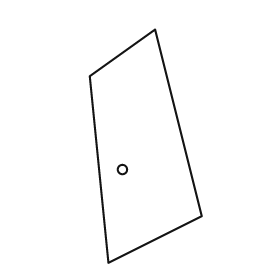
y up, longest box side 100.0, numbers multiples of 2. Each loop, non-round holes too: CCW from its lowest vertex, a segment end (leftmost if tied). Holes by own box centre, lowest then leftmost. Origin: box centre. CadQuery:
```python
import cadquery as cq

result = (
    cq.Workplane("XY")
    .moveTo(-16.0, -50.0)
    .lineTo(24.0, -30.0)
    .lineTo(4.0, 50.0)
    .lineTo(-24.0, 30.0)
    .close()
    .moveTo(-10.0, -10.0)
    .circle(2.0)
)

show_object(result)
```